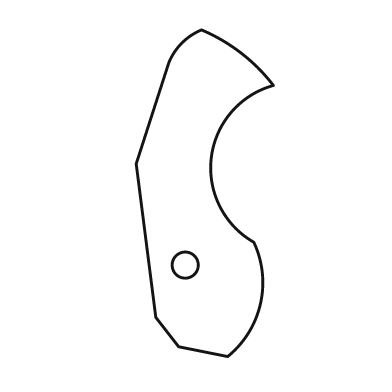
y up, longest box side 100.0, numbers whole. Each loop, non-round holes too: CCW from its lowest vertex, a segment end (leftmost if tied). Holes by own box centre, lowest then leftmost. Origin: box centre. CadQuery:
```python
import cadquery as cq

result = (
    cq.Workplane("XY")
    .moveTo(7.0, -50.0)
    .threePointArc((17.0, -34.0), (15.0, -15.0))
    .threePointArc((2.0, 11.0), (21.0, 33.0))
    .threePointArc((11.0, 43.0), (-1.0, 50.0))
    .threePointArc((-7.0, 46.0), (-11.0, 40.0))
    .lineTo(-21.0, 9.0)
    .lineTo(-15.0, -38.0)
    .lineTo(-8.0, -47.0)
    .close()
    .moveTo(-6.0, -22.0)
    .circle(4.0)
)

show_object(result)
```